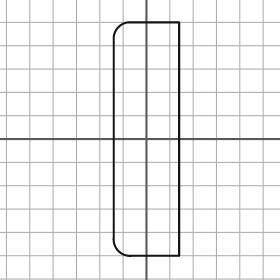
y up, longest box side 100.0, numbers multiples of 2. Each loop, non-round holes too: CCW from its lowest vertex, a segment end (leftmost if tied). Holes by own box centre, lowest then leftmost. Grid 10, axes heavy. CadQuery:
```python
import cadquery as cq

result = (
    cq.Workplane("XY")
    .moveTo(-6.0, -50.0)
    .lineTo(14.0, -50.0)
    .lineTo(14.0, 50.0)
    .lineTo(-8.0, 50.0)
    .threePointArc((-12.0, 48.0), (-14.0, 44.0))
    .lineTo(-14.0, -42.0)
    .threePointArc((-12.0, -48.0), (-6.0, -50.0))
    .close()
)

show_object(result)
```